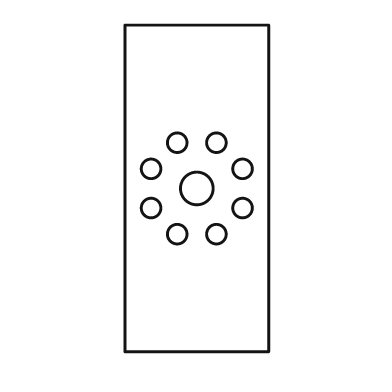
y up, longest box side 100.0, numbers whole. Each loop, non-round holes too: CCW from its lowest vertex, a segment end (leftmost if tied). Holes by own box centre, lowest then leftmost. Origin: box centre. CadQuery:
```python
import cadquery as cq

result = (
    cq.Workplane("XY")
    .moveTo(-22.0, -50.0)
    .lineTo(22.0, -50.0)
    .lineTo(22.0, 50.0)
    .lineTo(-22.0, 50.0)
    .close()
    .moveTo(-6.0, -14.0)
    .circle(3.0)
    .moveTo(6.0, -14.0)
    .circle(3.0)
    .moveTo(-14.0, -6.0)
    .circle(3.0)
    .moveTo(14.0, -6.0)
    .circle(3.0)
    .moveTo(0.0, 0.0)
    .circle(5.0)
    .moveTo(-14.0, 6.0)
    .circle(3.0)
    .moveTo(14.0, 6.0)
    .circle(3.0)
    .moveTo(-6.0, 14.0)
    .circle(3.0)
    .moveTo(6.0, 14.0)
    .circle(3.0)
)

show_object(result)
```